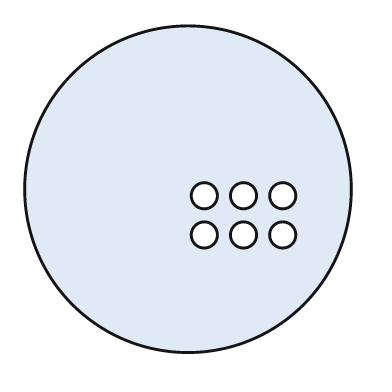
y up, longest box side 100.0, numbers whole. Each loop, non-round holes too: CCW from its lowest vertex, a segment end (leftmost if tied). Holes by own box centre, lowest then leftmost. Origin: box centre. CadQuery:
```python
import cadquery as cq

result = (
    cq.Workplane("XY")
    .moveTo(0.0, 0.0)
    .circle(50.0)
    .moveTo(5.0, -14.0)
    .circle(4.0)
    .moveTo(17.0, -14.0)
    .circle(4.0)
    .moveTo(29.0, -14.0)
    .circle(4.0)
    .moveTo(5.0, -2.0)
    .circle(4.0)
    .moveTo(17.0, -2.0)
    .circle(4.0)
    .moveTo(29.0, -2.0)
    .circle(4.0)
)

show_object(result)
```